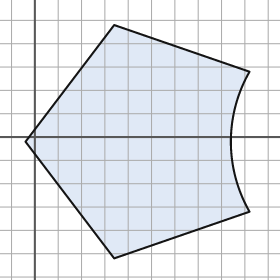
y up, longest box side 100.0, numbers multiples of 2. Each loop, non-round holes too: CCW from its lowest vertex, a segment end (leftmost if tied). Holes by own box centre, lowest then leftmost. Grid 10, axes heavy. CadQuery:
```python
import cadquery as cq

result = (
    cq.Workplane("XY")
    .moveTo(34.0, -52.0)
    .lineTo(92.0, -32.0)
    .threePointArc((84.0, -2.0), (92.0, 28.0))
    .lineTo(34.0, 48.0)
    .lineTo(-4.0, -2.0)
    .close()
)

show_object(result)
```